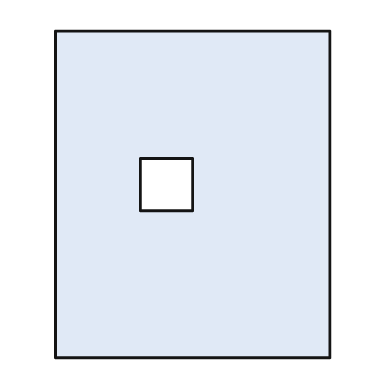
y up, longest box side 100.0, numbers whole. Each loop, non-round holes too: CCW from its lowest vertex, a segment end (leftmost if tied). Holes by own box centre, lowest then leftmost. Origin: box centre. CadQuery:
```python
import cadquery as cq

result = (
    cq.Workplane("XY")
    .moveTo(-42.0, -50.0)
    .lineTo(42.0, -50.0)
    .lineTo(42.0, 50.0)
    .lineTo(-42.0, 50.0)
    .close()
    .moveTo(-16.0, -5.0)
    .lineTo(0.0, -5.0)
    .lineTo(0.0, 11.0)
    .lineTo(-16.0, 11.0)
    .close()
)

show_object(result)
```